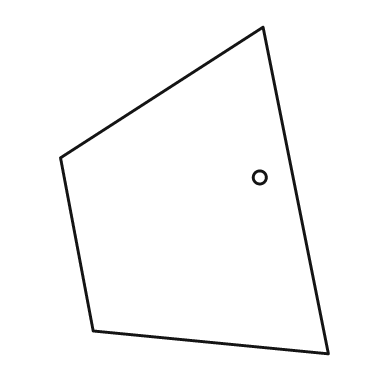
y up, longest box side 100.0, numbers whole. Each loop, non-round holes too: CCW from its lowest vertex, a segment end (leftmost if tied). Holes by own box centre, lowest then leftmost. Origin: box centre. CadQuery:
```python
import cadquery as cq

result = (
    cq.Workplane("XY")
    .moveTo(41.0, -50.0)
    .lineTo(21.0, 50.0)
    .lineTo(-41.0, 10.0)
    .lineTo(-31.0, -43.0)
    .close()
    .moveTo(20.0, 4.0)
    .circle(2.0)
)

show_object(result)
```